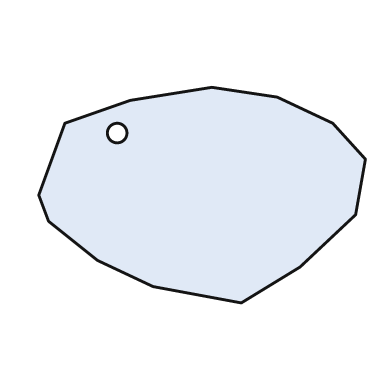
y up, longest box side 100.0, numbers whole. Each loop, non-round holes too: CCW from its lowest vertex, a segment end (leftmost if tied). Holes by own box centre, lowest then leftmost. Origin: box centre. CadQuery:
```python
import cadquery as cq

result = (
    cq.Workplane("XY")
    .moveTo(12.0, -33.0)
    .lineTo(30.0, -22.0)
    .lineTo(47.0, -6.0)
    .lineTo(50.0, 11.0)
    .lineTo(40.0, 22.0)
    .lineTo(23.0, 30.0)
    .lineTo(3.0, 33.0)
    .lineTo(-22.0, 29.0)
    .lineTo(-42.0, 22.0)
    .lineTo(-50.0, 0.0)
    .lineTo(-47.0, -8.0)
    .lineTo(-32.0, -20.0)
    .lineTo(-15.0, -28.0)
    .close()
    .moveTo(-26.0, 19.0)
    .circle(3.0)
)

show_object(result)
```